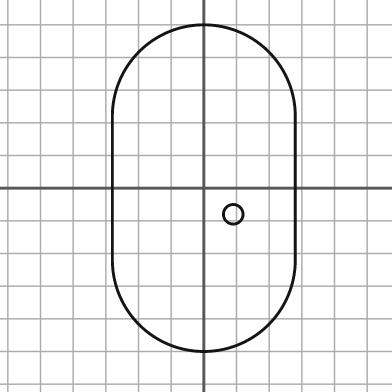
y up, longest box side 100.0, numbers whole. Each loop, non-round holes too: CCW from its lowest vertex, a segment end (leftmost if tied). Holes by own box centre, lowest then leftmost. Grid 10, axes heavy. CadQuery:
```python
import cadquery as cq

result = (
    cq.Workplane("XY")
    .moveTo(-28.0, -22.0)
    .threePointArc((0.0, -50.0), (28.0, -22.0))
    .lineTo(28.0, 22.0)
    .threePointArc((0.0, 50.0), (-28.0, 22.0))
    .close()
    .moveTo(9.0, -8.0)
    .circle(3.0)
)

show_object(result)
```